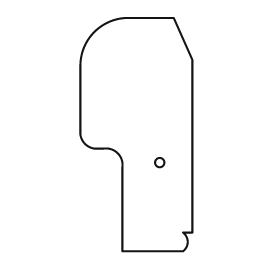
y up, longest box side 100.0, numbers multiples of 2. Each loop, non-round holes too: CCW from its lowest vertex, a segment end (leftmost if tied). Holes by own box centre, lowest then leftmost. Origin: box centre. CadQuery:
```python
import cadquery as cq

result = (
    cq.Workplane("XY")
    .moveTo(-6.0, -50.0)
    .lineTo(20.0, -50.0)
    .threePointArc((22.0, -46.0), (20.0, -42.0))
    .lineTo(24.0, -42.0)
    .lineTo(24.0, 32.0)
    .lineTo(16.0, 50.0)
    .lineTo(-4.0, 50.0)
    .threePointArc((-18.0, 44.0), (-24.0, 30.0))
    .lineTo(-24.0, 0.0)
    .threePointArc((-22.0, -4.0), (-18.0, -6.0))
    .lineTo(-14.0, -6.0)
    .threePointArc((-8.0, -8.0), (-6.0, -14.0))
    .close()
    .moveTo(10.0, -12.0)
    .circle(2.0)
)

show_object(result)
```